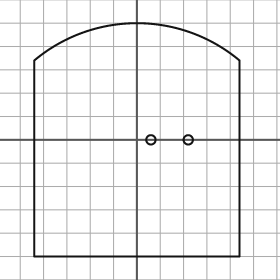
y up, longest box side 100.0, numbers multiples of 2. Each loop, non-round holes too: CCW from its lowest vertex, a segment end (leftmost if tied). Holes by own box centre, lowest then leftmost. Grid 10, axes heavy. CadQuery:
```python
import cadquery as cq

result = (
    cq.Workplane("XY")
    .moveTo(-44.0, -50.0)
    .lineTo(44.0, -50.0)
    .lineTo(44.0, 34.0)
    .threePointArc((0.0, 50.0), (-44.0, 34.0))
    .close()
    .moveTo(6.0, 0.0)
    .circle(2.0)
    .moveTo(22.0, 0.0)
    .circle(2.0)
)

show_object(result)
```